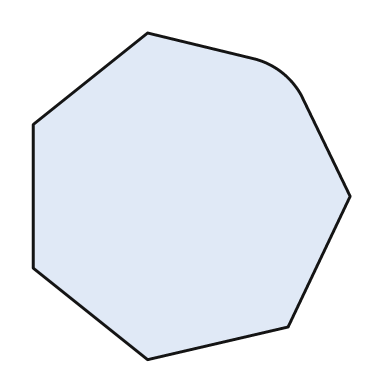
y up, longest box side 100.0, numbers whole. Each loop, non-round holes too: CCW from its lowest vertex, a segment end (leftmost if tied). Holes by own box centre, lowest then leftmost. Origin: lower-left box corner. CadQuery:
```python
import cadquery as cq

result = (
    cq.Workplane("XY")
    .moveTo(35.0, 0.0)
    .lineTo(78.0, 10.0)
    .lineTo(97.0, 50.0)
    .lineTo(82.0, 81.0)
    .threePointArc((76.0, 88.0), (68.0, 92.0))
    .lineTo(35.0, 100.0)
    .lineTo(0.0, 72.0)
    .lineTo(0.0, 28.0)
    .close()
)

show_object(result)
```